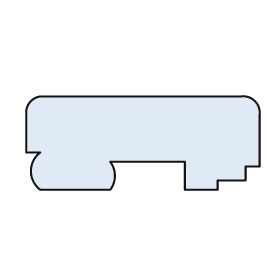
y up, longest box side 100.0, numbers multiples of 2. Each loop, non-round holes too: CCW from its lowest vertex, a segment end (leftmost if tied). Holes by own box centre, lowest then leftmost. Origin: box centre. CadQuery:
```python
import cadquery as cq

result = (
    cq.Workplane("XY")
    .moveTo(-44.0, -20.0)
    .lineTo(-14.0, -20.0)
    .threePointArc((-12.0, -14.0), (-14.0, -8.0))
    .lineTo(18.0, -8.0)
    .lineTo(18.0, -20.0)
    .lineTo(32.0, -20.0)
    .lineTo(32.0, -16.0)
    .lineTo(44.0, -16.0)
    .lineTo(44.0, -10.0)
    .lineTo(50.0, -10.0)
    .lineTo(50.0, 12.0)
    .threePointArc((48.0, 18.0), (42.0, 20.0))
    .lineTo(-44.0, 20.0)
    .threePointArc((-48.0, 18.0), (-50.0, 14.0))
    .lineTo(-50.0, -4.0)
    .lineTo(-44.0, -4.0)
    .threePointArc((-48.0, -12.0), (-44.0, -20.0))
    .close()
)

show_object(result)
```